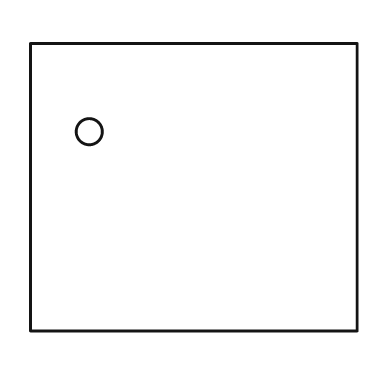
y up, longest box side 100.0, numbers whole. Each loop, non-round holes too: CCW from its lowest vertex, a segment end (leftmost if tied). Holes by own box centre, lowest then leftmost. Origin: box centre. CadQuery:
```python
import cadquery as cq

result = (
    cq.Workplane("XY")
    .moveTo(-50.0, -44.0)
    .lineTo(50.0, -44.0)
    .lineTo(50.0, 44.0)
    .lineTo(-50.0, 44.0)
    .close()
    .moveTo(-32.0, 17.0)
    .circle(4.0)
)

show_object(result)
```